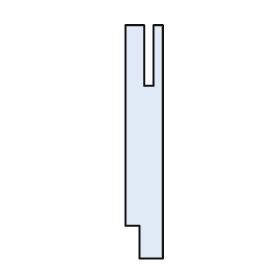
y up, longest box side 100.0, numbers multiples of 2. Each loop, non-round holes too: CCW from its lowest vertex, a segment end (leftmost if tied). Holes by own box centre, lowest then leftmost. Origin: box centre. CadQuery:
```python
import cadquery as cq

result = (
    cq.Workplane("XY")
    .moveTo(-2.0, -50.0)
    .lineTo(8.0, -50.0)
    .lineTo(8.0, 50.0)
    .lineTo(4.0, 50.0)
    .lineTo(4.0, 24.0)
    .lineTo(0.0, 24.0)
    .lineTo(0.0, 50.0)
    .lineTo(-8.0, 50.0)
    .lineTo(-8.0, -36.0)
    .lineTo(-2.0, -36.0)
    .close()
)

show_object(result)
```